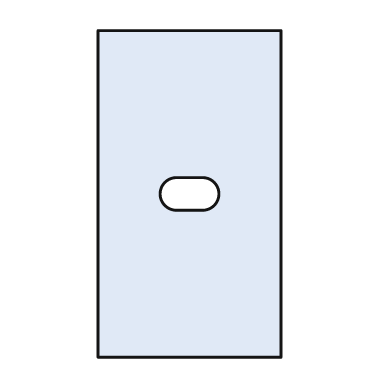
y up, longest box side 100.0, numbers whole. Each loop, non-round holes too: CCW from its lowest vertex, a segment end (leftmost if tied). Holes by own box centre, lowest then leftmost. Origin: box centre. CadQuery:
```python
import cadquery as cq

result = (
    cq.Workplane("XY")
    .moveTo(-28.0, -50.0)
    .lineTo(28.0, -50.0)
    .lineTo(28.0, 50.0)
    .lineTo(-28.0, 50.0)
    .close()
    .moveTo(-4.0, -5.0)
    .lineTo(4.0, -5.0)
    .threePointArc((9.0, 0.0), (4.0, 5.0))
    .lineTo(-4.0, 5.0)
    .threePointArc((-9.0, 0.0), (-4.0, -5.0))
    .close()
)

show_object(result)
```